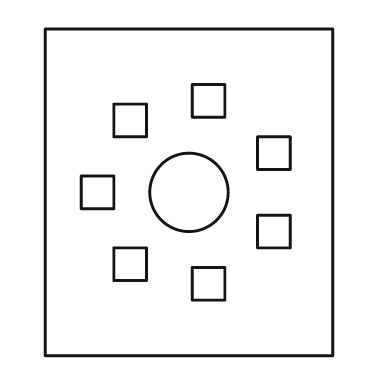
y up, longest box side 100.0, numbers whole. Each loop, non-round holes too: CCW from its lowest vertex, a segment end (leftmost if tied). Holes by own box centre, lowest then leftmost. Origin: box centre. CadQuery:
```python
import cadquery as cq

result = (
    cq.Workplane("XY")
    .moveTo(-44.0, -50.0)
    .lineTo(44.0, -50.0)
    .lineTo(44.0, 50.0)
    .lineTo(-44.0, 50.0)
    .close()
    .moveTo(1.0, -33.0)
    .lineTo(11.0, -33.0)
    .lineTo(11.0, -23.0)
    .lineTo(1.0, -23.0)
    .close()
    .moveTo(-23.0, -27.0)
    .lineTo(-13.0, -27.0)
    .lineTo(-13.0, -17.0)
    .lineTo(-23.0, -17.0)
    .close()
    .moveTo(21.0, -17.0)
    .lineTo(31.0, -17.0)
    .lineTo(31.0, -7.0)
    .lineTo(21.0, -7.0)
    .close()
    .moveTo(-33.0, -5.0)
    .lineTo(-23.0, -5.0)
    .lineTo(-23.0, 5.0)
    .lineTo(-33.0, 5.0)
    .close()
    .moveTo(0.0, 0.0)
    .circle(12.0)
    .moveTo(21.0, 7.0)
    .lineTo(31.0, 7.0)
    .lineTo(31.0, 17.0)
    .lineTo(21.0, 17.0)
    .close()
    .moveTo(-23.0, 17.0)
    .lineTo(-13.0, 17.0)
    .lineTo(-13.0, 27.0)
    .lineTo(-23.0, 27.0)
    .close()
    .moveTo(1.0, 23.0)
    .lineTo(11.0, 23.0)
    .lineTo(11.0, 33.0)
    .lineTo(1.0, 33.0)
    .close()
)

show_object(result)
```